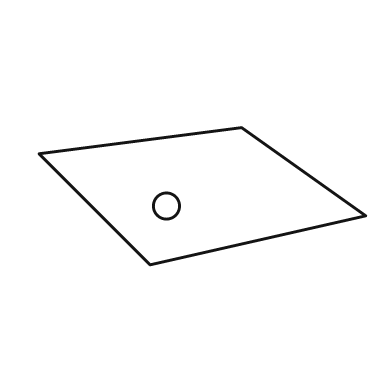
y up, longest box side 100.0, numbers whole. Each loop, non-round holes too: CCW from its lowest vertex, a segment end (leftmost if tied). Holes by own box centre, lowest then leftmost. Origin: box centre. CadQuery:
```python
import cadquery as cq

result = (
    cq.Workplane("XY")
    .moveTo(-16.0, -21.0)
    .lineTo(50.0, -6.0)
    .lineTo(12.0, 21.0)
    .lineTo(-50.0, 13.0)
    .close()
    .moveTo(-11.0, -3.0)
    .circle(4.0)
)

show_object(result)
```